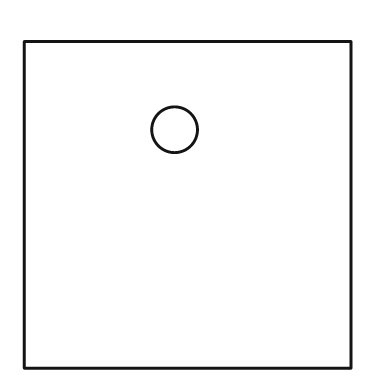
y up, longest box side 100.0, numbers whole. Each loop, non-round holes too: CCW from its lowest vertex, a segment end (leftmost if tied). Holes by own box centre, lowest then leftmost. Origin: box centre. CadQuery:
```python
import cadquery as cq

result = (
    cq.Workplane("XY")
    .moveTo(-50.0, -50.0)
    .lineTo(50.0, -50.0)
    .lineTo(50.0, 50.0)
    .lineTo(-50.0, 50.0)
    .close()
    .moveTo(-4.0, 23.0)
    .circle(7.0)
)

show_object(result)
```